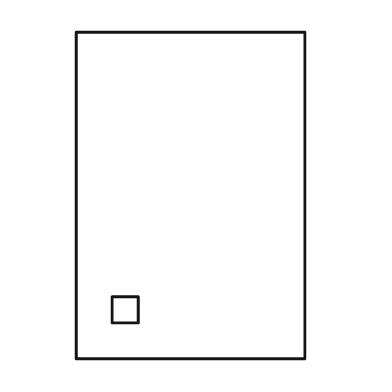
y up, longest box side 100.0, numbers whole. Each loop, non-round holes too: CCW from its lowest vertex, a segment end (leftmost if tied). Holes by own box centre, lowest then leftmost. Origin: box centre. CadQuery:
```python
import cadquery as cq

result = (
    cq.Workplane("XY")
    .moveTo(-35.0, -50.0)
    .lineTo(35.0, -50.0)
    .lineTo(35.0, 50.0)
    .lineTo(-35.0, 50.0)
    .close()
    .moveTo(-24.0, -39.0)
    .lineTo(-16.0, -39.0)
    .lineTo(-16.0, -31.0)
    .lineTo(-24.0, -31.0)
    .close()
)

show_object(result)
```